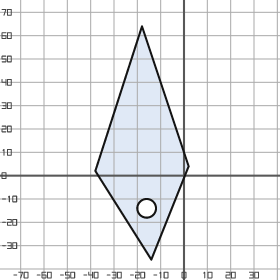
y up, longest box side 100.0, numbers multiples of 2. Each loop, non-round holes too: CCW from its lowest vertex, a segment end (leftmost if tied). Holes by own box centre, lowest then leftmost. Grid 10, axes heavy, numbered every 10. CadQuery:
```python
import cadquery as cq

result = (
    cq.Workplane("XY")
    .moveTo(-14.0, -36.0)
    .lineTo(2.0, 4.0)
    .lineTo(-18.0, 64.0)
    .lineTo(-38.0, 2.0)
    .close()
    .moveTo(-16.0, -14.0)
    .circle(4.0)
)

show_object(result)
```